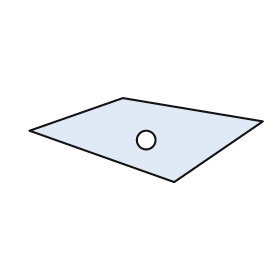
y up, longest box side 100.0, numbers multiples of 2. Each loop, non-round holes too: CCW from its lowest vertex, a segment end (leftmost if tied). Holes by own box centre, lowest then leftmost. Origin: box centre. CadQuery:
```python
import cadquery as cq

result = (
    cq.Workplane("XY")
    .moveTo(12.0, -18.0)
    .lineTo(50.0, 8.0)
    .lineTo(-10.0, 18.0)
    .lineTo(-50.0, 4.0)
    .close()
    .moveTo(0.0, 0.0)
    .circle(4.0)
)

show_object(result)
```